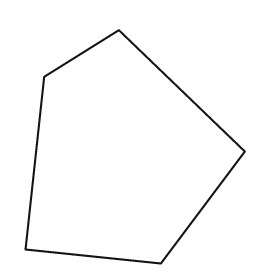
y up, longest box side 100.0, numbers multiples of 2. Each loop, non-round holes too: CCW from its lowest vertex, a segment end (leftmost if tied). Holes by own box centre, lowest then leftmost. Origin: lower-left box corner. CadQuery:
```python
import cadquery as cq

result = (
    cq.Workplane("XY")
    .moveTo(58.0, 0.0)
    .lineTo(94.0, 48.0)
    .lineTo(40.0, 100.0)
    .lineTo(8.0, 80.0)
    .lineTo(0.0, 6.0)
    .close()
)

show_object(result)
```